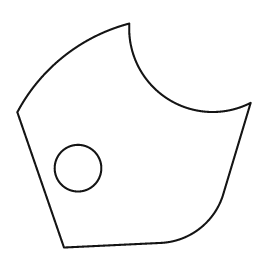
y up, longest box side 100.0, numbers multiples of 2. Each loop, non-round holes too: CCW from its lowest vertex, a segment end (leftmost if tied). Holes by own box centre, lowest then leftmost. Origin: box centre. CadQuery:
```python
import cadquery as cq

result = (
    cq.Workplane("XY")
    .moveTo(-30.0, -48.0)
    .lineTo(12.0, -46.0)
    .threePointArc((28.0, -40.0), (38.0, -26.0))
    .lineTo(50.0, 14.0)
    .threePointArc((14.0, 16.0), (-2.0, 48.0))
    .threePointArc((-30.0, 34.0), (-50.0, 10.0))
    .close()
    .moveTo(-24.0, -14.0)
    .circle(10.0)
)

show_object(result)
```